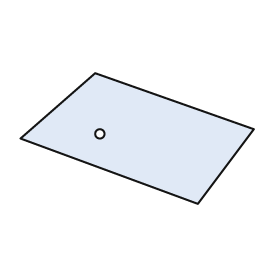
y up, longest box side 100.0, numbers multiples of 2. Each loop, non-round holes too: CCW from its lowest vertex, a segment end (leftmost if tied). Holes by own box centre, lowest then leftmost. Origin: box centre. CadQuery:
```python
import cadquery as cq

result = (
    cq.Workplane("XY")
    .moveTo(26.0, -28.0)
    .lineTo(50.0, 4.0)
    .lineTo(-18.0, 28.0)
    .lineTo(-50.0, 0.0)
    .close()
    .moveTo(-16.0, 2.0)
    .circle(2.0)
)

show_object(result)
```